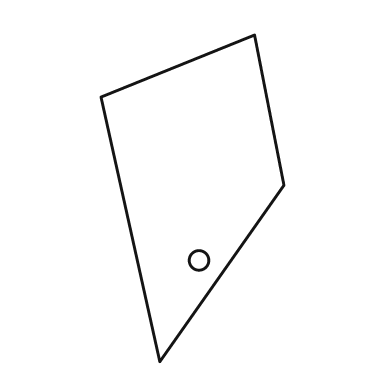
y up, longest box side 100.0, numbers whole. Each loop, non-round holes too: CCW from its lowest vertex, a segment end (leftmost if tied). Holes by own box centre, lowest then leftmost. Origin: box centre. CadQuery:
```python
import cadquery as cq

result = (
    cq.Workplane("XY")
    .moveTo(-10.0, -50.0)
    .lineTo(28.0, 4.0)
    .lineTo(19.0, 50.0)
    .lineTo(-28.0, 31.0)
    .close()
    .moveTo(2.0, -19.0)
    .circle(3.0)
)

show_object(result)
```